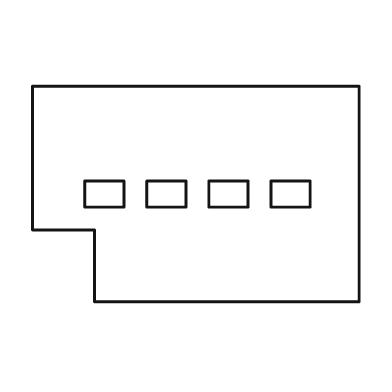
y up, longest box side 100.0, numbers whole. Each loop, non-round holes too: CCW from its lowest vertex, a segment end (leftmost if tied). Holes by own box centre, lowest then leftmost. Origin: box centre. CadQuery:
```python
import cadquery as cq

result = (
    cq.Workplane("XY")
    .moveTo(-31.0, -33.0)
    .lineTo(50.0, -33.0)
    .lineTo(50.0, 33.0)
    .lineTo(-50.0, 33.0)
    .lineTo(-50.0, -11.0)
    .lineTo(-31.0, -11.0)
    .close()
    .moveTo(-34.0, -4.0)
    .lineTo(-22.0, -4.0)
    .lineTo(-22.0, 4.0)
    .lineTo(-34.0, 4.0)
    .close()
    .moveTo(-15.0, -4.0)
    .lineTo(-3.0, -4.0)
    .lineTo(-3.0, 4.0)
    .lineTo(-15.0, 4.0)
    .close()
    .moveTo(4.0, -4.0)
    .lineTo(16.0, -4.0)
    .lineTo(16.0, 4.0)
    .lineTo(4.0, 4.0)
    .close()
    .moveTo(23.0, -4.0)
    .lineTo(35.0, -4.0)
    .lineTo(35.0, 4.0)
    .lineTo(23.0, 4.0)
    .close()
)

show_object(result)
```